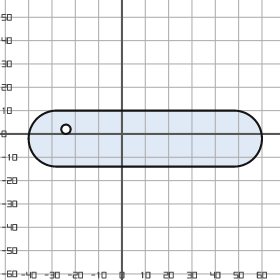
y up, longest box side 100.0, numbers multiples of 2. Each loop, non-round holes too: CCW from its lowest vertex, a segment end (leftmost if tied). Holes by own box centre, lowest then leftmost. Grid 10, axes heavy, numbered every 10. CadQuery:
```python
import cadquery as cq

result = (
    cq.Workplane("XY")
    .moveTo(-28.0, -14.0)
    .lineTo(48.0, -14.0)
    .threePointArc((60.0, -2.0), (48.0, 10.0))
    .lineTo(-28.0, 10.0)
    .threePointArc((-40.0, -2.0), (-28.0, -14.0))
    .close()
    .moveTo(-24.0, 2.0)
    .circle(2.0)
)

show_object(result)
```